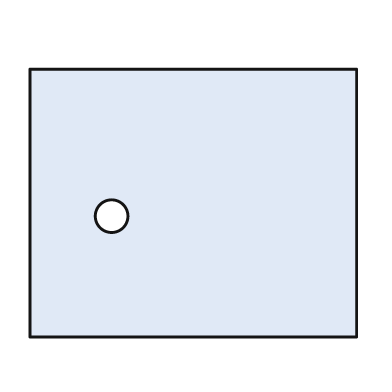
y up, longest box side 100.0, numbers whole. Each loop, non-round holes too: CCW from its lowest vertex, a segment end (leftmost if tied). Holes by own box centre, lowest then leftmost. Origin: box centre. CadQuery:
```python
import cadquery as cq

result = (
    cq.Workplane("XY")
    .moveTo(-50.0, -41.0)
    .lineTo(50.0, -41.0)
    .lineTo(50.0, 41.0)
    .lineTo(-50.0, 41.0)
    .close()
    .moveTo(-25.0, -4.0)
    .circle(5.0)
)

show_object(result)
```